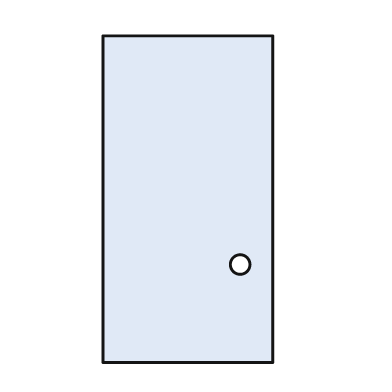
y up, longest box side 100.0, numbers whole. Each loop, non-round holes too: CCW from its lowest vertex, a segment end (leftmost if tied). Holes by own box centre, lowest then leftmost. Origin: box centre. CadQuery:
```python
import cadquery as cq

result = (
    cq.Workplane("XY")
    .moveTo(-26.0, -50.0)
    .lineTo(26.0, -50.0)
    .lineTo(26.0, 50.0)
    .lineTo(-26.0, 50.0)
    .close()
    .moveTo(16.0, -20.0)
    .circle(3.0)
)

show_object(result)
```